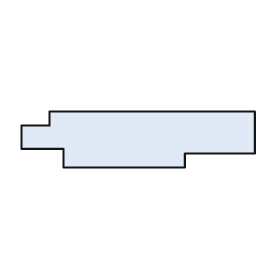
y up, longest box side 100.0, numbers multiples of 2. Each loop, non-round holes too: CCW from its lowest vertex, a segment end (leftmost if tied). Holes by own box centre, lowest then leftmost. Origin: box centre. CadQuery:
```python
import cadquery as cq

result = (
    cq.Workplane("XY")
    .moveTo(-32.0, -12.0)
    .lineTo(20.0, -12.0)
    .lineTo(20.0, -6.0)
    .lineTo(50.0, -6.0)
    .lineTo(50.0, 12.0)
    .lineTo(-38.0, 12.0)
    .lineTo(-38.0, 6.0)
    .lineTo(-50.0, 6.0)
    .lineTo(-50.0, -4.0)
    .lineTo(-32.0, -4.0)
    .close()
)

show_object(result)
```